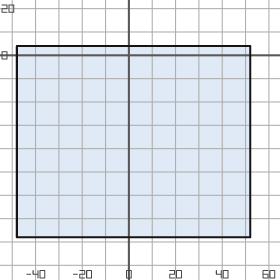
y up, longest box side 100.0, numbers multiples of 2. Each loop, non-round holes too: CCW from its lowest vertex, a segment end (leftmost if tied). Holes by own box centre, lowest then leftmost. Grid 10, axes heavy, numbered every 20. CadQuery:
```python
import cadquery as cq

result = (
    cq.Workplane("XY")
    .moveTo(-48.0, -78.0)
    .lineTo(52.0, -78.0)
    .lineTo(52.0, 4.0)
    .lineTo(-48.0, 4.0)
    .close()
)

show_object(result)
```